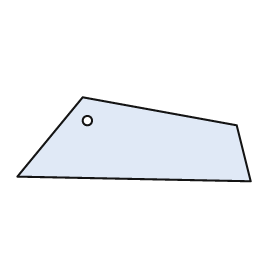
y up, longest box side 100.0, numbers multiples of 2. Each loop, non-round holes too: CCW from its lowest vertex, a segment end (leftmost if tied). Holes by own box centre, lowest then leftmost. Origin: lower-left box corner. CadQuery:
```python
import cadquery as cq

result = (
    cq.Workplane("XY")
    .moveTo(100.0, 0.0)
    .lineTo(94.0, 24.0)
    .lineTo(28.0, 36.0)
    .lineTo(0.0, 2.0)
    .close()
    .moveTo(30.0, 26.0)
    .circle(2.0)
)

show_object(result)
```